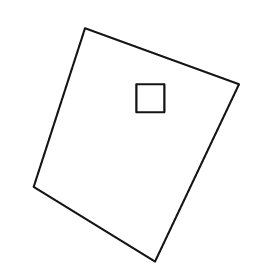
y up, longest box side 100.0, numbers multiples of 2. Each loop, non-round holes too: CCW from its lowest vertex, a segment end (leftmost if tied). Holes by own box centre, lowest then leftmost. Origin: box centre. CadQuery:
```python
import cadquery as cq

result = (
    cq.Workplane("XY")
    .moveTo(8.0, -50.0)
    .lineTo(44.0, 26.0)
    .lineTo(-22.0, 50.0)
    .lineTo(-44.0, -18.0)
    .close()
    .moveTo(0.0, 14.0)
    .lineTo(12.0, 14.0)
    .lineTo(12.0, 26.0)
    .lineTo(0.0, 26.0)
    .close()
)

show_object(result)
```